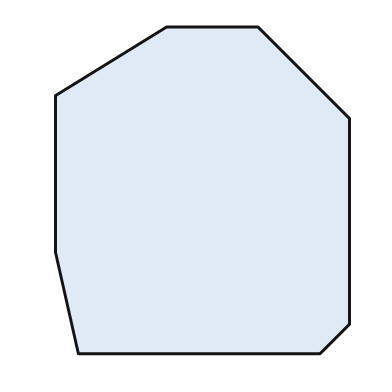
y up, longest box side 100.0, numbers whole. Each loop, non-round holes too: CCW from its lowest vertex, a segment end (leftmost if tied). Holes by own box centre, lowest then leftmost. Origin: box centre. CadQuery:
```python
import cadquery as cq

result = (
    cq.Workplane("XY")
    .moveTo(-38.0, -50.0)
    .lineTo(36.0, -50.0)
    .lineTo(45.0, -41.0)
    .lineTo(45.0, 22.0)
    .lineTo(17.0, 50.0)
    .lineTo(-11.0, 50.0)
    .lineTo(-45.0, 29.0)
    .lineTo(-45.0, -19.0)
    .close()
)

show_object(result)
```